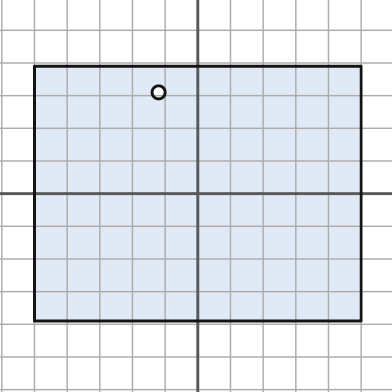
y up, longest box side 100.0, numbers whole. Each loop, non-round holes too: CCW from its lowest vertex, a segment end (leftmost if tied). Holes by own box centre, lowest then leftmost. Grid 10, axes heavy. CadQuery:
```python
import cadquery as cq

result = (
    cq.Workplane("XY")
    .moveTo(-50.0, -39.0)
    .lineTo(50.0, -39.0)
    .lineTo(50.0, 39.0)
    .lineTo(-50.0, 39.0)
    .close()
    .moveTo(-12.0, 31.0)
    .circle(2.0)
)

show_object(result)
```